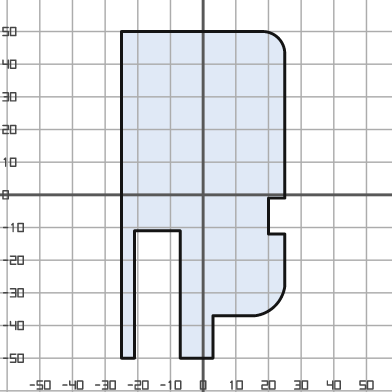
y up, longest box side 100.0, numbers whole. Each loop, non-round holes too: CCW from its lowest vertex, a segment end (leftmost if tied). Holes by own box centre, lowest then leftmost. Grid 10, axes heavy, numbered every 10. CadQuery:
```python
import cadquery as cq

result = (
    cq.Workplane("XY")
    .moveTo(-25.0, -50.0)
    .lineTo(-21.0, -50.0)
    .lineTo(-21.0, -11.0)
    .lineTo(-7.0, -11.0)
    .lineTo(-7.0, -50.0)
    .lineTo(3.0, -50.0)
    .lineTo(3.0, -37.0)
    .lineTo(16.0, -37.0)
    .threePointArc((22.0, -34.0), (25.0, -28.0))
    .lineTo(25.0, -12.0)
    .lineTo(20.0, -12.0)
    .lineTo(20.0, -1.0)
    .lineTo(25.0, -1.0)
    .lineTo(25.0, 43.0)
    .threePointArc((23.0, 48.0), (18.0, 50.0))
    .lineTo(-25.0, 50.0)
    .close()
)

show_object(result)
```